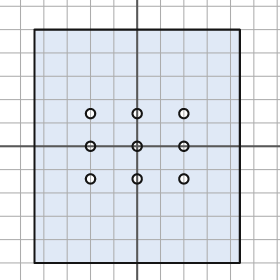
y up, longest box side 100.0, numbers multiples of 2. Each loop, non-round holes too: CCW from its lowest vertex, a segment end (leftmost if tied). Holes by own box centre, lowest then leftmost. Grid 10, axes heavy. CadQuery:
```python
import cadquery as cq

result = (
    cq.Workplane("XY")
    .moveTo(-44.0, -50.0)
    .lineTo(44.0, -50.0)
    .lineTo(44.0, 50.0)
    .lineTo(-44.0, 50.0)
    .close()
    .moveTo(-20.0, -14.0)
    .circle(2.0)
    .moveTo(0.0, -14.0)
    .circle(2.0)
    .moveTo(20.0, -14.0)
    .circle(2.0)
    .moveTo(-20.0, 0.0)
    .circle(2.0)
    .moveTo(0.0, 0.0)
    .circle(2.0)
    .moveTo(20.0, 0.0)
    .circle(2.0)
    .moveTo(-20.0, 14.0)
    .circle(2.0)
    .moveTo(0.0, 14.0)
    .circle(2.0)
    .moveTo(20.0, 14.0)
    .circle(2.0)
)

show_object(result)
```